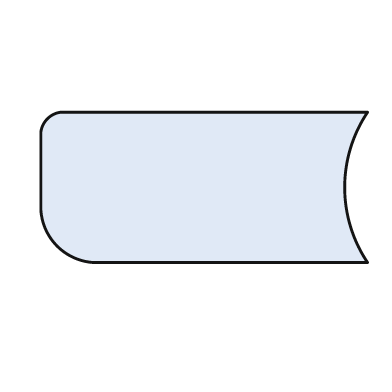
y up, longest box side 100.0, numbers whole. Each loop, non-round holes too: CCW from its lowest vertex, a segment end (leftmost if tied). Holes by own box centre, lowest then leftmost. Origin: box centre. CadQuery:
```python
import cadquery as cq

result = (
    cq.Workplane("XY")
    .moveTo(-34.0, -23.0)
    .lineTo(50.0, -23.0)
    .threePointArc((43.0, 0.0), (50.0, 23.0))
    .lineTo(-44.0, 23.0)
    .threePointArc((-48.0, 21.0), (-50.0, 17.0))
    .lineTo(-50.0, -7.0)
    .threePointArc((-45.0, -18.0), (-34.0, -23.0))
    .close()
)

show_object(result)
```